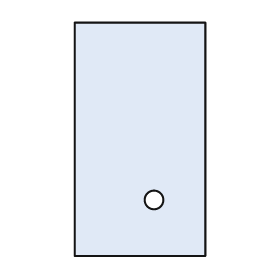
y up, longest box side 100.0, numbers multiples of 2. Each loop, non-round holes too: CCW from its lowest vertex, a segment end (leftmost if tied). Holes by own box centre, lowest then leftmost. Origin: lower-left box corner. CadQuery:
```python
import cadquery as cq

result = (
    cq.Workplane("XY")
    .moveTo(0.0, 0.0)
    .lineTo(56.0, 0.0)
    .lineTo(56.0, 100.0)
    .lineTo(0.0, 100.0)
    .close()
    .moveTo(34.0, 24.0)
    .circle(4.0)
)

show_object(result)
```